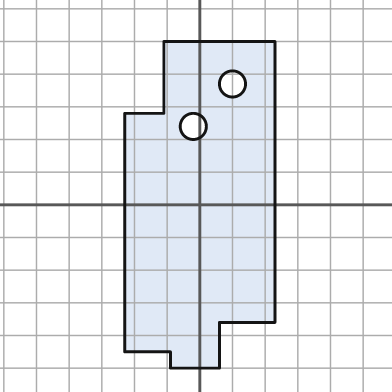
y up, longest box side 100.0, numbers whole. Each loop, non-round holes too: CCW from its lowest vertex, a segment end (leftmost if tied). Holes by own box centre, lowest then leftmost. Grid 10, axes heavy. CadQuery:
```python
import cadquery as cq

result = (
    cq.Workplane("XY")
    .moveTo(-9.0, -50.0)
    .lineTo(6.0, -50.0)
    .lineTo(6.0, -36.0)
    .lineTo(23.0, -36.0)
    .lineTo(23.0, 50.0)
    .lineTo(-11.0, 50.0)
    .lineTo(-11.0, 28.0)
    .lineTo(-23.0, 28.0)
    .lineTo(-23.0, -45.0)
    .lineTo(-9.0, -45.0)
    .close()
    .moveTo(-2.0, 24.0)
    .circle(4.0)
    .moveTo(10.0, 37.0)
    .circle(4.0)
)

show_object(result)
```